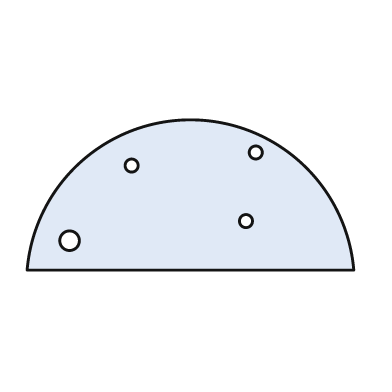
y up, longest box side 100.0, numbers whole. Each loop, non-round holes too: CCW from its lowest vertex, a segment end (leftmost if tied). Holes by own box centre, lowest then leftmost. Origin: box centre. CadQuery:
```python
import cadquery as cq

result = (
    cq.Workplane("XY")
    .moveTo(-50.0, -23.0)
    .lineTo(50.0, -23.0)
    .threePointArc((0.0, 23.0), (-50.0, -23.0))
    .close()
    .moveTo(-37.0, -14.0)
    .circle(3.0)
    .moveTo(17.0, -8.0)
    .circle(2.0)
    .moveTo(-18.0, 9.0)
    .circle(2.0)
    .moveTo(20.0, 13.0)
    .circle(2.0)
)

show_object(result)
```